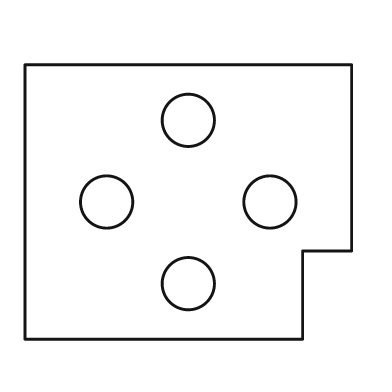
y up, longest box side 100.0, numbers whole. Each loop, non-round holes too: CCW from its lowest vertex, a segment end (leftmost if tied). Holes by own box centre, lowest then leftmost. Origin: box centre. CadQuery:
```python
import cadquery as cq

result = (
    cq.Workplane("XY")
    .moveTo(-50.0, -42.0)
    .lineTo(35.0, -42.0)
    .lineTo(35.0, -15.0)
    .lineTo(50.0, -15.0)
    .lineTo(50.0, 42.0)
    .lineTo(-50.0, 42.0)
    .close()
    .moveTo(0.0, -25.0)
    .circle(8.0)
    .moveTo(-25.0, 0.0)
    .circle(8.0)
    .moveTo(25.0, 0.0)
    .circle(8.0)
    .moveTo(0.0, 25.0)
    .circle(8.0)
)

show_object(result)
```